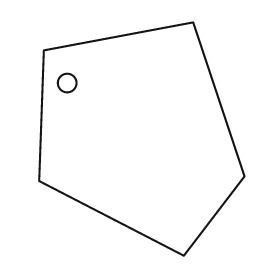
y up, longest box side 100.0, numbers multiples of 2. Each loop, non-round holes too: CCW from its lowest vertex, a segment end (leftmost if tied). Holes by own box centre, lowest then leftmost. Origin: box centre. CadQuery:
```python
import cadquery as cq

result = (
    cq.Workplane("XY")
    .moveTo(18.0, -50.0)
    .lineTo(44.0, -16.0)
    .lineTo(22.0, 50.0)
    .lineTo(-42.0, 38.0)
    .lineTo(-44.0, -18.0)
    .close()
    .moveTo(-32.0, 24.0)
    .circle(4.0)
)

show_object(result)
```